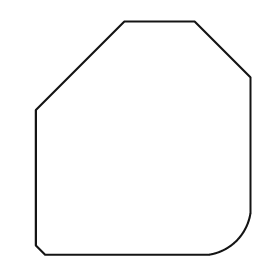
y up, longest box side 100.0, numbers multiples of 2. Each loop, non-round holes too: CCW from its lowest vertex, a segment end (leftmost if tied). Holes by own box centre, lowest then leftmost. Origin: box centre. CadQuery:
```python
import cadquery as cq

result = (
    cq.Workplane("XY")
    .moveTo(-42.0, -50.0)
    .lineTo(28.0, -50.0)
    .threePointArc((40.0, -44.0), (46.0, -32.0))
    .lineTo(46.0, 26.0)
    .lineTo(22.0, 50.0)
    .lineTo(-8.0, 50.0)
    .lineTo(-46.0, 12.0)
    .lineTo(-46.0, -46.0)
    .close()
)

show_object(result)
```